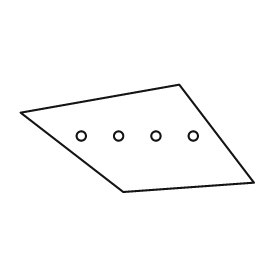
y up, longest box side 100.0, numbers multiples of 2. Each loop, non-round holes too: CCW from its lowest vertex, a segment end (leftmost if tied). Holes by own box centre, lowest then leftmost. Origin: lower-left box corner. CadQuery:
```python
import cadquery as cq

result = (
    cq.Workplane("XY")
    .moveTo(44.0, 0.0)
    .lineTo(100.0, 4.0)
    .lineTo(68.0, 46.0)
    .lineTo(0.0, 34.0)
    .close()
    .moveTo(26.0, 24.0)
    .circle(2.0)
    .moveTo(42.0, 24.0)
    .circle(2.0)
    .moveTo(58.0, 24.0)
    .circle(2.0)
    .moveTo(74.0, 24.0)
    .circle(2.0)
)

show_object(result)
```